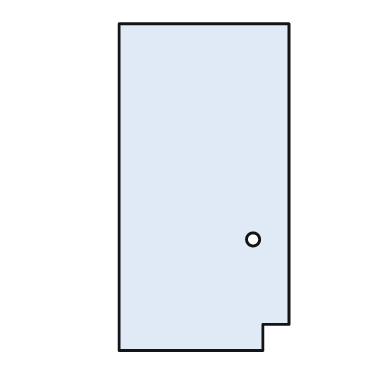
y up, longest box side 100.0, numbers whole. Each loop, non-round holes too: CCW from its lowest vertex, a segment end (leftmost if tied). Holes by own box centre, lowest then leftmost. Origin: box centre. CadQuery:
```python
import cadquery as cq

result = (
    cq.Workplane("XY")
    .moveTo(-26.0, -50.0)
    .lineTo(18.0, -50.0)
    .lineTo(18.0, -42.0)
    .lineTo(26.0, -42.0)
    .lineTo(26.0, 50.0)
    .lineTo(-26.0, 50.0)
    .close()
    .moveTo(15.0, -16.0)
    .circle(2.0)
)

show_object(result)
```